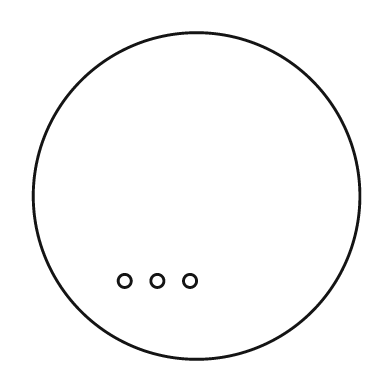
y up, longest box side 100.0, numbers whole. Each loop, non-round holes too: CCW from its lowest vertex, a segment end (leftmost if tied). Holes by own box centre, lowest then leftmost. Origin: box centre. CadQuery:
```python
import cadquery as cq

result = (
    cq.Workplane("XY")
    .moveTo(0.0, 0.0)
    .circle(50.0)
    .moveTo(-22.0, -26.0)
    .circle(2.0)
    .moveTo(-12.0, -26.0)
    .circle(2.0)
    .moveTo(-2.0, -26.0)
    .circle(2.0)
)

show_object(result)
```